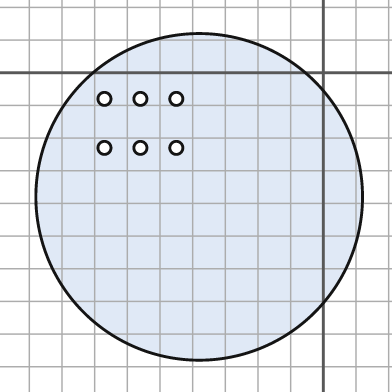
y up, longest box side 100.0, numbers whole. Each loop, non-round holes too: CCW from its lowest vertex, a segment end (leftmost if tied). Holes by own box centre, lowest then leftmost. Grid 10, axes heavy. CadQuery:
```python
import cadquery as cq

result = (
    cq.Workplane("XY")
    .moveTo(-38.0, -38.0)
    .circle(50.0)
    .moveTo(-67.0, -23.0)
    .circle(2.0)
    .moveTo(-56.0, -23.0)
    .circle(2.0)
    .moveTo(-45.0, -23.0)
    .circle(2.0)
    .moveTo(-67.0, -8.0)
    .circle(2.0)
    .moveTo(-56.0, -8.0)
    .circle(2.0)
    .moveTo(-45.0, -8.0)
    .circle(2.0)
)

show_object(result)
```